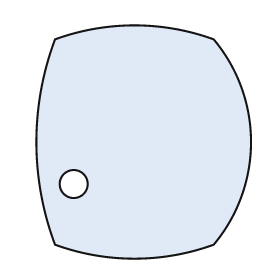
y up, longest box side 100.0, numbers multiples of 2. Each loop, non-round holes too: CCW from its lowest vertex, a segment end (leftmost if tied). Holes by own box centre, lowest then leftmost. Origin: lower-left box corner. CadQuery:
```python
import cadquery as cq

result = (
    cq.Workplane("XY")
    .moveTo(8.0, 6.0)
    .threePointArc((42.0, 0.0), (76.0, 6.0))
    .threePointArc((92.0, 50.0), (76.0, 94.0))
    .threePointArc((42.0, 100.0), (8.0, 94.0))
    .threePointArc((0.0, 50.0), (8.0, 6.0))
    .close()
    .moveTo(16.0, 32.0)
    .circle(6.0)
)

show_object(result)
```